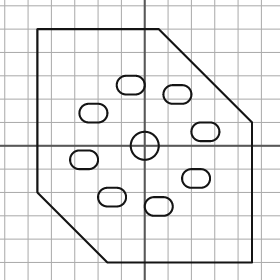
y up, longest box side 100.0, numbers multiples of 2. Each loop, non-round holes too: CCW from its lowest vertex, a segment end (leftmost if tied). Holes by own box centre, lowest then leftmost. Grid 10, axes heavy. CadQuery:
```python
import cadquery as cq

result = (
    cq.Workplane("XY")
    .moveTo(-16.0, -50.0)
    .lineTo(46.0, -50.0)
    .lineTo(46.0, 10.0)
    .lineTo(6.0, 50.0)
    .lineTo(-46.0, 50.0)
    .lineTo(-46.0, -20.0)
    .close()
    .moveTo(4.0, -30.0)
    .lineTo(8.0, -30.0)
    .threePointArc((12.0, -26.0), (8.0, -22.0))
    .lineTo(4.0, -22.0)
    .threePointArc((0.0, -26.0), (4.0, -30.0))
    .close()
    .moveTo(-16.0, -26.0)
    .lineTo(-12.0, -26.0)
    .threePointArc((-8.0, -22.0), (-12.0, -18.0))
    .lineTo(-16.0, -18.0)
    .threePointArc((-20.0, -22.0), (-16.0, -26.0))
    .close()
    .moveTo(20.0, -18.0)
    .lineTo(24.0, -18.0)
    .threePointArc((28.0, -14.0), (24.0, -10.0))
    .lineTo(20.0, -10.0)
    .threePointArc((16.0, -14.0), (20.0, -18.0))
    .close()
    .moveTo(-28.0, -10.0)
    .lineTo(-24.0, -10.0)
    .threePointArc((-20.0, -6.0), (-24.0, -2.0))
    .lineTo(-28.0, -2.0)
    .threePointArc((-32.0, -6.0), (-28.0, -10.0))
    .close()
    .moveTo(0.0, 0.0)
    .circle(6.0)
    .moveTo(24.0, 2.0)
    .lineTo(28.0, 2.0)
    .threePointArc((32.0, 6.0), (28.0, 10.0))
    .lineTo(24.0, 10.0)
    .threePointArc((20.0, 6.0), (24.0, 2.0))
    .close()
    .moveTo(-24.0, 10.0)
    .lineTo(-20.0, 10.0)
    .threePointArc((-16.0, 14.0), (-20.0, 18.0))
    .lineTo(-24.0, 18.0)
    .threePointArc((-28.0, 14.0), (-24.0, 10.0))
    .close()
    .moveTo(12.0, 18.0)
    .lineTo(16.0, 18.0)
    .threePointArc((20.0, 22.0), (16.0, 26.0))
    .lineTo(12.0, 26.0)
    .threePointArc((8.0, 22.0), (12.0, 18.0))
    .close()
    .moveTo(-8.0, 22.0)
    .lineTo(-4.0, 22.0)
    .threePointArc((0.0, 26.0), (-4.0, 30.0))
    .lineTo(-8.0, 30.0)
    .threePointArc((-12.0, 26.0), (-8.0, 22.0))
    .close()
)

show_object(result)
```